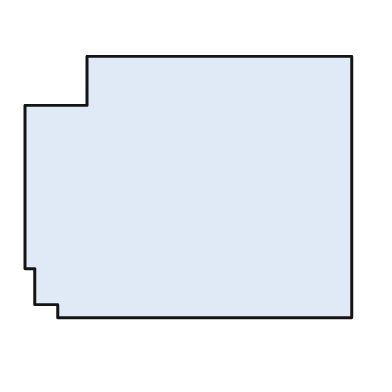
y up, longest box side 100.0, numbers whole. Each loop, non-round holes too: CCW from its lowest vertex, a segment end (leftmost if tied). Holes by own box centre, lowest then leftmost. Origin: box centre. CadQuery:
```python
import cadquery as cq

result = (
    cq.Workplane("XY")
    .moveTo(-40.0, -40.0)
    .lineTo(50.0, -40.0)
    .lineTo(50.0, 40.0)
    .lineTo(-31.0, 40.0)
    .lineTo(-31.0, 25.0)
    .lineTo(-50.0, 25.0)
    .lineTo(-50.0, -25.0)
    .lineTo(-47.0, -25.0)
    .lineTo(-47.0, -36.0)
    .lineTo(-40.0, -36.0)
    .close()
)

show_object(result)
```